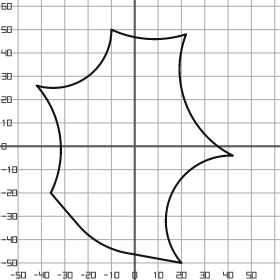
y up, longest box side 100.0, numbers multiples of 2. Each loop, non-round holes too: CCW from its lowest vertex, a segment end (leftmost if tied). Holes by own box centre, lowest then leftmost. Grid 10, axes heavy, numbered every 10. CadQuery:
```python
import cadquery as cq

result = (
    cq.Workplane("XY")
    .moveTo(20.0, -50.0)
    .threePointArc((16.0, -20.0), (42.0, -4.0))
    .threePointArc((22.0, 18.0), (22.0, 48.0))
    .threePointArc((6.0, 46.0), (-10.0, 50.0))
    .threePointArc((-20.0, 30.0), (-42.0, 26.0))
    .threePointArc((-32.0, 4.0), (-36.0, -20.0))
    .lineTo(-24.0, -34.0)
    .threePointArc((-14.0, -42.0), (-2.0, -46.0))
    .close()
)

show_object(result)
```